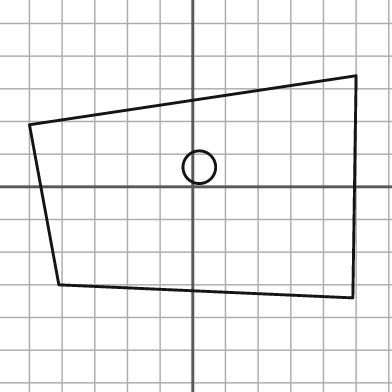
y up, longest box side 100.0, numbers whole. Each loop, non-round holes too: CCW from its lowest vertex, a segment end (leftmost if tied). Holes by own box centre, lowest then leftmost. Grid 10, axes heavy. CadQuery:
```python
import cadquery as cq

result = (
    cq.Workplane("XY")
    .moveTo(49.0, -34.0)
    .lineTo(50.0, 34.0)
    .lineTo(-50.0, 19.0)
    .lineTo(-41.0, -30.0)
    .close()
    .moveTo(2.0, 6.0)
    .circle(5.0)
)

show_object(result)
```